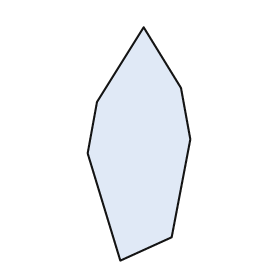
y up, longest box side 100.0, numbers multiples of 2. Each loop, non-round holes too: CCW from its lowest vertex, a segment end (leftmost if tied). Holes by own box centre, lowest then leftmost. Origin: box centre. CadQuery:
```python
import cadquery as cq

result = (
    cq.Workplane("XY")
    .moveTo(-8.0, -50.0)
    .lineTo(14.0, -40.0)
    .lineTo(22.0, 2.0)
    .lineTo(18.0, 24.0)
    .lineTo(2.0, 50.0)
    .lineTo(-18.0, 18.0)
    .lineTo(-22.0, -4.0)
    .close()
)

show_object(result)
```